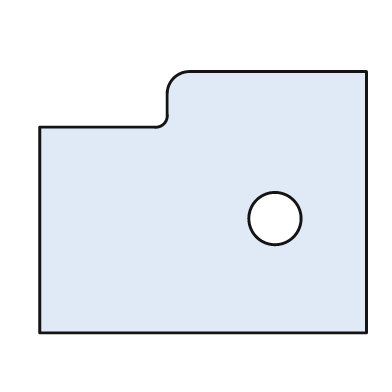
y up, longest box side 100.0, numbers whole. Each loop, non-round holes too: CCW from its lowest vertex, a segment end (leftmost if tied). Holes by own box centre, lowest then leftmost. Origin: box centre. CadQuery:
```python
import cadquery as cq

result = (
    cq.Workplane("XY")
    .moveTo(-50.0, -40.0)
    .lineTo(50.0, -40.0)
    .lineTo(50.0, 40.0)
    .lineTo(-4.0, 40.0)
    .threePointArc((-9.0, 38.0), (-11.0, 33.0))
    .lineTo(-11.0, 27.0)
    .threePointArc((-12.0, 24.0), (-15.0, 23.0))
    .lineTo(-50.0, 23.0)
    .close()
    .moveTo(22.0, -5.0)
    .circle(8.0)
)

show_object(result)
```